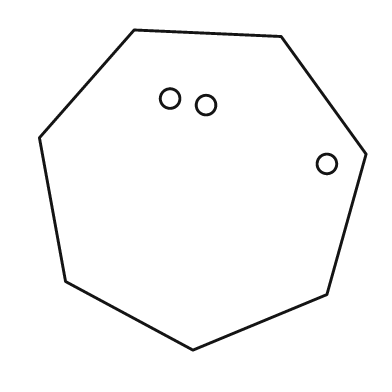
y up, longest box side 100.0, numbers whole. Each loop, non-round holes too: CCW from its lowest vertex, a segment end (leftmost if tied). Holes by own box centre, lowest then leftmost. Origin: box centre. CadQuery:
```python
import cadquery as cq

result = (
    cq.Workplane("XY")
    .moveTo(-3.0, -49.0)
    .lineTo(38.0, -32.0)
    .lineTo(50.0, 11.0)
    .lineTo(24.0, 47.0)
    .lineTo(-21.0, 49.0)
    .lineTo(-50.0, 16.0)
    .lineTo(-42.0, -28.0)
    .close()
    .moveTo(38.0, 8.0)
    .circle(3.0)
    .moveTo(1.0, 26.0)
    .circle(3.0)
    .moveTo(-10.0, 28.0)
    .circle(3.0)
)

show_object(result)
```